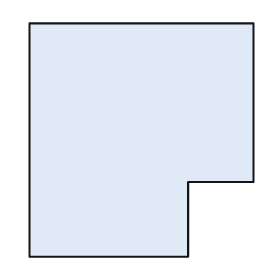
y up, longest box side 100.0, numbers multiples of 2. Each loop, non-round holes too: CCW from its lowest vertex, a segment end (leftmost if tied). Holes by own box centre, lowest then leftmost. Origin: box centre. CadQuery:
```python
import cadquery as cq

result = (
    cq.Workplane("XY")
    .moveTo(-48.0, -50.0)
    .lineTo(20.0, -50.0)
    .lineTo(20.0, -18.0)
    .lineTo(48.0, -18.0)
    .lineTo(48.0, 50.0)
    .lineTo(-48.0, 50.0)
    .close()
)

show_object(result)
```